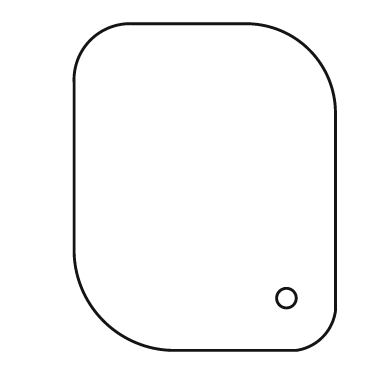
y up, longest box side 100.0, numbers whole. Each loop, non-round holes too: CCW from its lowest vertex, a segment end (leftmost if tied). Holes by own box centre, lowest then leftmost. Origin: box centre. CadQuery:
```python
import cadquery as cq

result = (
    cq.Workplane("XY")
    .moveTo(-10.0, -50.0)
    .lineTo(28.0, -50.0)
    .threePointArc((36.0, -46.0), (40.0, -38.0))
    .lineTo(40.0, 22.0)
    .threePointArc((32.0, 42.0), (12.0, 50.0))
    .lineTo(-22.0, 50.0)
    .threePointArc((-35.0, 45.0), (-40.0, 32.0))
    .lineTo(-40.0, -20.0)
    .threePointArc((-31.0, -41.0), (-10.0, -50.0))
    .close()
    .moveTo(25.0, -34.0)
    .circle(3.0)
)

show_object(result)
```